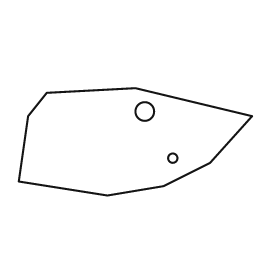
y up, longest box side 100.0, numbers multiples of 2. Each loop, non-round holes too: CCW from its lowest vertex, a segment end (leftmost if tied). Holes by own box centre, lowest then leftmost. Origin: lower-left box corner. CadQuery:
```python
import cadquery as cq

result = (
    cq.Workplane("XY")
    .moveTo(38.0, 0.0)
    .lineTo(62.0, 4.0)
    .lineTo(82.0, 14.0)
    .lineTo(100.0, 34.0)
    .lineTo(50.0, 46.0)
    .lineTo(12.0, 44.0)
    .lineTo(4.0, 34.0)
    .lineTo(0.0, 6.0)
    .close()
    .moveTo(66.0, 16.0)
    .circle(2.0)
    .moveTo(54.0, 36.0)
    .circle(4.0)
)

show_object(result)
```